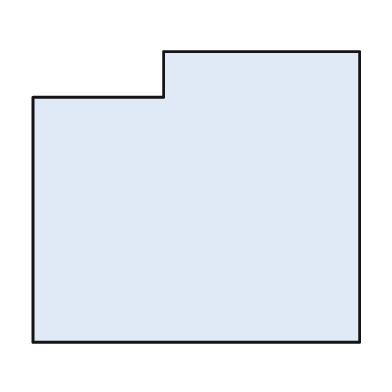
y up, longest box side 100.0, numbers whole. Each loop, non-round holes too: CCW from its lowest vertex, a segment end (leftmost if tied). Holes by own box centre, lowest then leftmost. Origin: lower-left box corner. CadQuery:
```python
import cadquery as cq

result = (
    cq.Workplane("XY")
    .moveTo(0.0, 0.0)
    .lineTo(100.0, 0.0)
    .lineTo(100.0, 89.0)
    .lineTo(40.0, 89.0)
    .lineTo(40.0, 75.0)
    .lineTo(0.0, 75.0)
    .close()
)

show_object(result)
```